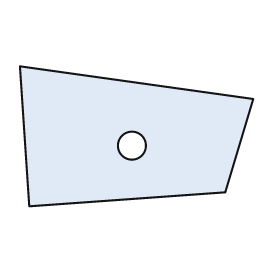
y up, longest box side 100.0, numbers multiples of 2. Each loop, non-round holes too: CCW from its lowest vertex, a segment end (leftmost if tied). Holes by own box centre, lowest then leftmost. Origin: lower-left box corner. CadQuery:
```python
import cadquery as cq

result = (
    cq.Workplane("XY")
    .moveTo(4.0, 0.0)
    .lineTo(88.0, 6.0)
    .lineTo(100.0, 46.0)
    .lineTo(0.0, 60.0)
    .close()
    .moveTo(48.0, 26.0)
    .circle(6.0)
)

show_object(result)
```